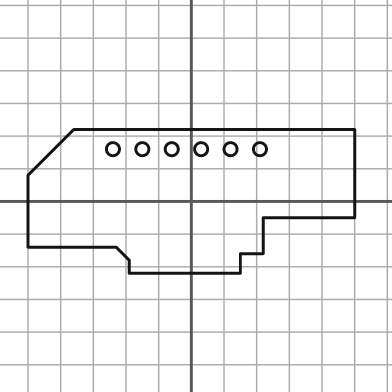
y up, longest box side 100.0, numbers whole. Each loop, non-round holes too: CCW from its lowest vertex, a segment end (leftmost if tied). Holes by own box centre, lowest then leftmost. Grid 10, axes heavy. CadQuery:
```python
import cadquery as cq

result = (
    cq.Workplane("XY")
    .moveTo(-19.0, -22.0)
    .lineTo(15.0, -22.0)
    .lineTo(15.0, -16.0)
    .lineTo(22.0, -16.0)
    .lineTo(22.0, -5.0)
    .lineTo(50.0, -5.0)
    .lineTo(50.0, 22.0)
    .lineTo(-36.0, 22.0)
    .lineTo(-50.0, 8.0)
    .lineTo(-50.0, -14.0)
    .lineTo(-23.0, -14.0)
    .lineTo(-19.0, -18.0)
    .close()
    .moveTo(-24.0, 16.0)
    .circle(2.0)
    .moveTo(-15.0, 16.0)
    .circle(2.0)
    .moveTo(-6.0, 16.0)
    .circle(2.0)
    .moveTo(3.0, 16.0)
    .circle(2.0)
    .moveTo(12.0, 16.0)
    .circle(2.0)
    .moveTo(21.0, 16.0)
    .circle(2.0)
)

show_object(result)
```